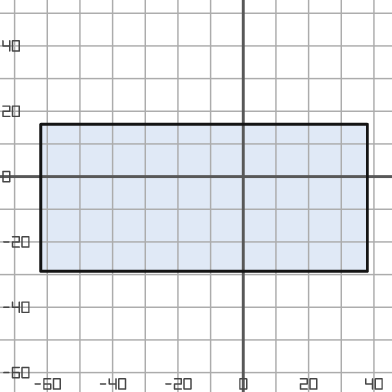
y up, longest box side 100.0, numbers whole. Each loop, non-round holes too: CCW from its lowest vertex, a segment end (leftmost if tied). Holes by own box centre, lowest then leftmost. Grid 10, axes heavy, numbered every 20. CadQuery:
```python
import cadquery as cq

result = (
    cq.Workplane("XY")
    .moveTo(-62.0, -29.0)
    .lineTo(38.0, -29.0)
    .lineTo(38.0, 16.0)
    .lineTo(-62.0, 16.0)
    .close()
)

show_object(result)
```